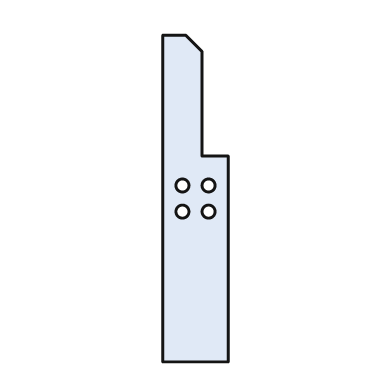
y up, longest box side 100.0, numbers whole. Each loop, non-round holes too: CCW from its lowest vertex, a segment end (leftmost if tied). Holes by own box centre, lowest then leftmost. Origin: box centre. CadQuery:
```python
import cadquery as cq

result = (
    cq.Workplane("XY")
    .moveTo(-10.0, -50.0)
    .lineTo(10.0, -50.0)
    .lineTo(10.0, 13.0)
    .lineTo(2.0, 13.0)
    .lineTo(2.0, 45.0)
    .lineTo(-3.0, 50.0)
    .lineTo(-10.0, 50.0)
    .close()
    .moveTo(-4.0, -4.0)
    .circle(2.0)
    .moveTo(4.0, -4.0)
    .circle(2.0)
    .moveTo(-4.0, 4.0)
    .circle(2.0)
    .moveTo(4.0, 4.0)
    .circle(2.0)
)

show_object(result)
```